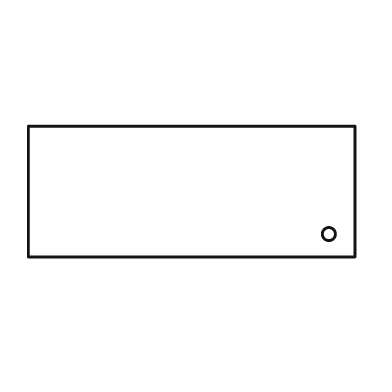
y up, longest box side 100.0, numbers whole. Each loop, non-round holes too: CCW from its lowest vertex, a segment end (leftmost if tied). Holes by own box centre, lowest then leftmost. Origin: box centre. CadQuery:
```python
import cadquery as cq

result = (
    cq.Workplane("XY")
    .moveTo(-50.0, -20.0)
    .lineTo(50.0, -20.0)
    .lineTo(50.0, 20.0)
    .lineTo(-50.0, 20.0)
    .close()
    .moveTo(42.0, -13.0)
    .circle(2.0)
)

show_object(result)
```